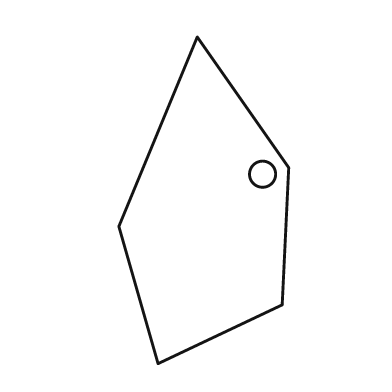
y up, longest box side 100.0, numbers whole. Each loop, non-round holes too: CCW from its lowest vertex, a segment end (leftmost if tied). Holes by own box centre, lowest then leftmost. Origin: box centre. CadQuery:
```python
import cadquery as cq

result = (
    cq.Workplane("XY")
    .moveTo(-14.0, -50.0)
    .lineTo(24.0, -32.0)
    .lineTo(26.0, 10.0)
    .lineTo(-2.0, 50.0)
    .lineTo(-26.0, -8.0)
    .close()
    .moveTo(18.0, 8.0)
    .circle(4.0)
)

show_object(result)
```